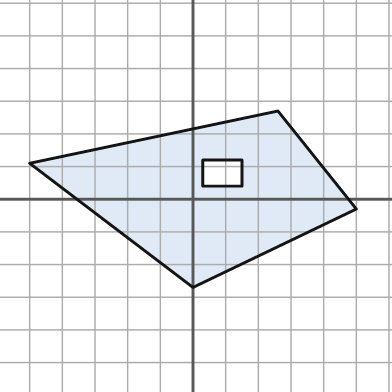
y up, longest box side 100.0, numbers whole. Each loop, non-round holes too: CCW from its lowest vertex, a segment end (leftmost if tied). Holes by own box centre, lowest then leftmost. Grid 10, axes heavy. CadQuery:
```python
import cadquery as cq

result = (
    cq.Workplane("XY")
    .moveTo(0.0, -27.0)
    .lineTo(50.0, -3.0)
    .lineTo(26.0, 27.0)
    .lineTo(-50.0, 11.0)
    .close()
    .moveTo(3.0, 4.0)
    .lineTo(15.0, 4.0)
    .lineTo(15.0, 12.0)
    .lineTo(3.0, 12.0)
    .close()
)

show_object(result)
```